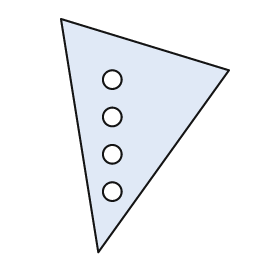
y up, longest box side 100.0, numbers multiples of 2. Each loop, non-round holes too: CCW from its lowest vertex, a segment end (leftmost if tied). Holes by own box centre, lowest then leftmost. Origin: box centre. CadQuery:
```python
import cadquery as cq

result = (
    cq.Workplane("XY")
    .moveTo(-20.0, -50.0)
    .lineTo(36.0, 28.0)
    .lineTo(-36.0, 50.0)
    .close()
    .moveTo(-14.0, -24.0)
    .circle(4.0)
    .moveTo(-14.0, -8.0)
    .circle(4.0)
    .moveTo(-14.0, 8.0)
    .circle(4.0)
    .moveTo(-14.0, 24.0)
    .circle(4.0)
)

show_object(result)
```